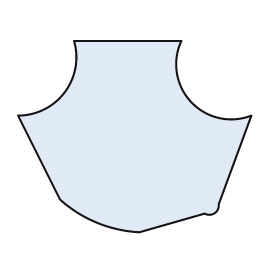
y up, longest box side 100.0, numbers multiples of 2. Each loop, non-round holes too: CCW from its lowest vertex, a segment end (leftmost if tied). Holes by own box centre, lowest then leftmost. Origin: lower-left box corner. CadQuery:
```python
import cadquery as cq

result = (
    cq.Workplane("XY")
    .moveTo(52.0, 0.0)
    .lineTo(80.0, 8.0)
    .threePointArc((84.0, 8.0), (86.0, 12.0))
    .lineTo(100.0, 50.0)
    .threePointArc((74.0, 56.0), (70.0, 82.0))
    .lineTo(24.0, 82.0)
    .threePointArc((20.0, 60.0), (0.0, 50.0))
    .lineTo(18.0, 14.0)
    .threePointArc((34.0, 4.0), (52.0, 0.0))
    .close()
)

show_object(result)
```